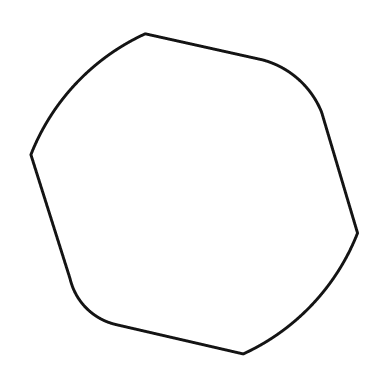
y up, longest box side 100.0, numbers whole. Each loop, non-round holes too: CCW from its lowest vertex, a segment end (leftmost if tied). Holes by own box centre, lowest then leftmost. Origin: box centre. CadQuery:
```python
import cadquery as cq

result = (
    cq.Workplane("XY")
    .moveTo(15.0, -49.0)
    .threePointArc((36.0, -34.0), (50.0, -12.0))
    .lineTo(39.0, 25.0)
    .threePointArc((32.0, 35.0), (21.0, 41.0))
    .lineTo(-15.0, 49.0)
    .threePointArc((-36.0, 34.0), (-50.0, 12.0))
    .lineTo(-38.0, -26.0)
    .threePointArc((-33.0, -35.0), (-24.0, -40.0))
    .close()
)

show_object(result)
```